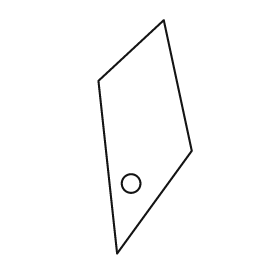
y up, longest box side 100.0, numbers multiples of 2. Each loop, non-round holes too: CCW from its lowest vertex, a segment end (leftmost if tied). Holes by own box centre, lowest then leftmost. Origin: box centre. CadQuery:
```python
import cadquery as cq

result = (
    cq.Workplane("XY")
    .moveTo(-12.0, -50.0)
    .lineTo(20.0, -6.0)
    .lineTo(8.0, 50.0)
    .lineTo(-20.0, 24.0)
    .close()
    .moveTo(-6.0, -20.0)
    .circle(4.0)
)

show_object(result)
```